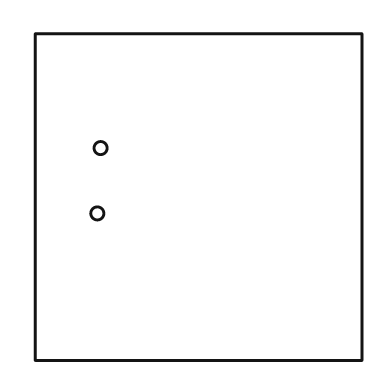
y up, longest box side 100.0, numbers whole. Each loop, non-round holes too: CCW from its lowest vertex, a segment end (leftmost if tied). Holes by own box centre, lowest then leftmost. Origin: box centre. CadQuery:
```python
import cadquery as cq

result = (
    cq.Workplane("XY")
    .moveTo(-50.0, -50.0)
    .lineTo(50.0, -50.0)
    .lineTo(50.0, 50.0)
    .lineTo(-50.0, 50.0)
    .close()
    .moveTo(-31.0, -5.0)
    .circle(2.0)
    .moveTo(-30.0, 15.0)
    .circle(2.0)
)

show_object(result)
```